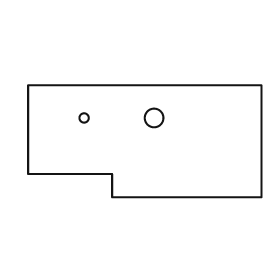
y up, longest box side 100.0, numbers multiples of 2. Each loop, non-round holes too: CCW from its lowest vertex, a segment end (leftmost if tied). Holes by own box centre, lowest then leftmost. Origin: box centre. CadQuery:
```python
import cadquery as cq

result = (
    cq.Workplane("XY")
    .moveTo(-14.0, -24.0)
    .lineTo(50.0, -24.0)
    .lineTo(50.0, 24.0)
    .lineTo(-50.0, 24.0)
    .lineTo(-50.0, -14.0)
    .lineTo(-14.0, -14.0)
    .close()
    .moveTo(-26.0, 10.0)
    .circle(2.0)
    .moveTo(4.0, 10.0)
    .circle(4.0)
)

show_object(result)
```